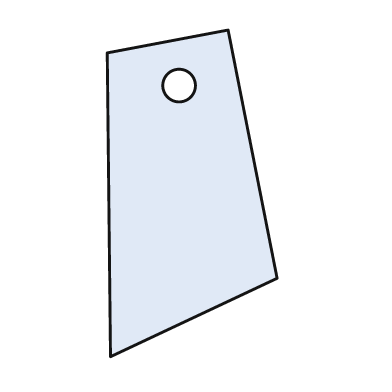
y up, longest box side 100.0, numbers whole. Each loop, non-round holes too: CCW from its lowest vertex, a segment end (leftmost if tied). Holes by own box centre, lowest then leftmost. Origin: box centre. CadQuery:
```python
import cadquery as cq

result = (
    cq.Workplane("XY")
    .moveTo(-25.0, -50.0)
    .lineTo(26.0, -26.0)
    .lineTo(11.0, 50.0)
    .lineTo(-26.0, 43.0)
    .close()
    .moveTo(-4.0, 33.0)
    .circle(5.0)
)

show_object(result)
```